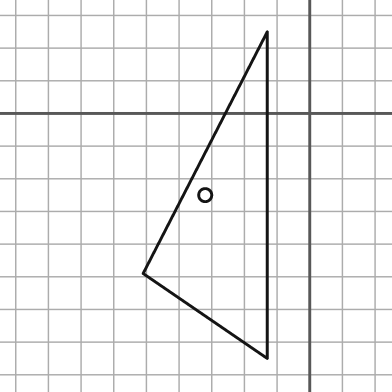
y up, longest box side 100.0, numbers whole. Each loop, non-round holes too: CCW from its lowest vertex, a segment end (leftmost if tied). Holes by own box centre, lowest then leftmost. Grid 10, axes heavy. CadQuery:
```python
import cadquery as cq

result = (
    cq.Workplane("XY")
    .moveTo(-13.0, -75.0)
    .lineTo(-13.0, 25.0)
    .lineTo(-51.0, -49.0)
    .close()
    .moveTo(-32.0, -25.0)
    .circle(2.0)
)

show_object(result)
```